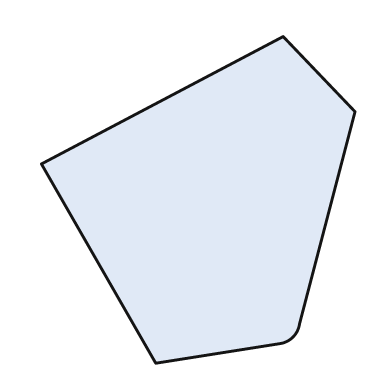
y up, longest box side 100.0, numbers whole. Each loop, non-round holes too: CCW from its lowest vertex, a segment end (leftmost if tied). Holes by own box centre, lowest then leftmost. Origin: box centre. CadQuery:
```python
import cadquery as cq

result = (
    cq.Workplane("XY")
    .moveTo(-13.0, -50.0)
    .lineTo(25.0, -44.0)
    .threePointArc((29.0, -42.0), (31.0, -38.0))
    .lineTo(48.0, 27.0)
    .lineTo(26.0, 50.0)
    .lineTo(-48.0, 11.0)
    .close()
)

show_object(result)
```